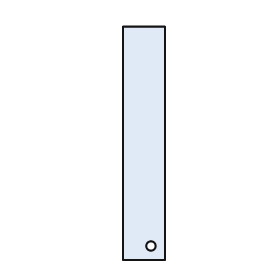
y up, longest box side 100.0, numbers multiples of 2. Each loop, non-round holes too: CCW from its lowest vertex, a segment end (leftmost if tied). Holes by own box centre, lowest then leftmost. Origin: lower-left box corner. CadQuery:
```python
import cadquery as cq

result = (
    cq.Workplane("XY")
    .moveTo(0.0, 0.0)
    .lineTo(18.0, 0.0)
    .lineTo(18.0, 100.0)
    .lineTo(0.0, 100.0)
    .close()
    .moveTo(12.0, 6.0)
    .circle(2.0)
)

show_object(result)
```